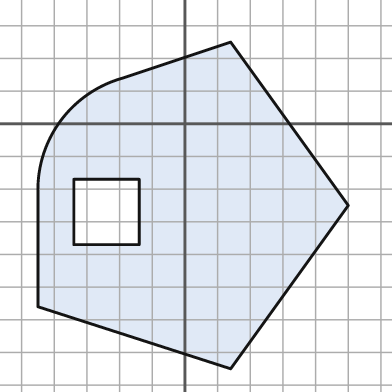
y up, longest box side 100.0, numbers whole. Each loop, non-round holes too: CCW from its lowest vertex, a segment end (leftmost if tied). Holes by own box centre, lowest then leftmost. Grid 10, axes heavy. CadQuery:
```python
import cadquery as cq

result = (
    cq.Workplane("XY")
    .moveTo(14.0, -75.0)
    .lineTo(50.0, -25.0)
    .lineTo(14.0, 25.0)
    .lineTo(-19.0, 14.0)
    .threePointArc((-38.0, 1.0), (-45.0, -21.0))
    .lineTo(-45.0, -56.0)
    .close()
    .moveTo(-34.0, -37.0)
    .lineTo(-14.0, -37.0)
    .lineTo(-14.0, -17.0)
    .lineTo(-34.0, -17.0)
    .close()
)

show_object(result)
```